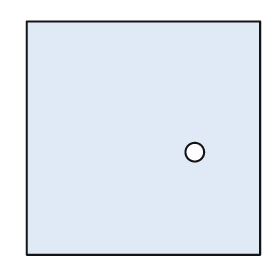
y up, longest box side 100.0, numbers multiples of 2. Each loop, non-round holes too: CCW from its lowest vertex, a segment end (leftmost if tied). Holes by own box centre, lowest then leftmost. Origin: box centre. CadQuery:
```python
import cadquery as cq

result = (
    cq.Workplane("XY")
    .moveTo(-50.0, -50.0)
    .lineTo(50.0, -50.0)
    .lineTo(50.0, 50.0)
    .lineTo(-50.0, 50.0)
    .close()
    .moveTo(22.0, -6.0)
    .circle(4.0)
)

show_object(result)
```